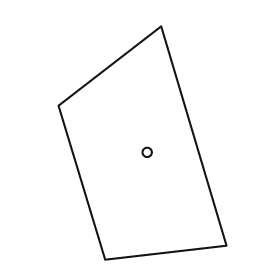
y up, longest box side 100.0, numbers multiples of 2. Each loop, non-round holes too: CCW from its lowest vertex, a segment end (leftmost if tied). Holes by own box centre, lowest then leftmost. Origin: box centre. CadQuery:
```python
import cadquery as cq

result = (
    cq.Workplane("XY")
    .moveTo(-16.0, -50.0)
    .lineTo(36.0, -44.0)
    .lineTo(8.0, 50.0)
    .lineTo(-36.0, 16.0)
    .close()
    .moveTo(2.0, -4.0)
    .circle(2.0)
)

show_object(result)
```